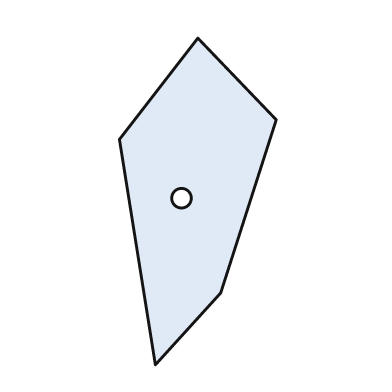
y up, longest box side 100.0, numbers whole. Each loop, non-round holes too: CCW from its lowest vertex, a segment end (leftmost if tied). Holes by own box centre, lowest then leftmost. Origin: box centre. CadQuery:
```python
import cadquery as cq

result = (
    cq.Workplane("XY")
    .moveTo(-13.0, -50.0)
    .lineTo(7.0, -28.0)
    .lineTo(24.0, 25.0)
    .lineTo(0.0, 50.0)
    .lineTo(-24.0, 19.0)
    .close()
    .moveTo(-5.0, 1.0)
    .circle(3.0)
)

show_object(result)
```